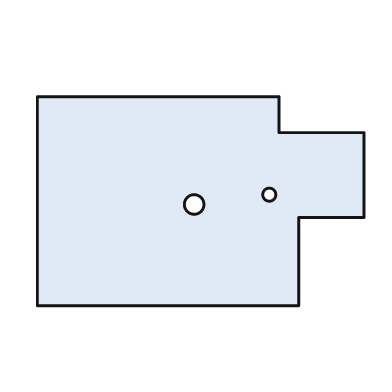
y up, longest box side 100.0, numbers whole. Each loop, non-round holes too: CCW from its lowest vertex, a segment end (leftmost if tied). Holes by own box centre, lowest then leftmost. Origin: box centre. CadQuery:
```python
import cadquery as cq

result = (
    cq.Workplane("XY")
    .moveTo(-50.0, -32.0)
    .lineTo(30.0, -32.0)
    .lineTo(30.0, -5.0)
    .lineTo(50.0, -5.0)
    .lineTo(50.0, 21.0)
    .lineTo(24.0, 21.0)
    .lineTo(24.0, 32.0)
    .lineTo(-50.0, 32.0)
    .close()
    .moveTo(-2.0, -1.0)
    .circle(3.0)
    .moveTo(21.0, 2.0)
    .circle(2.0)
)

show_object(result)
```